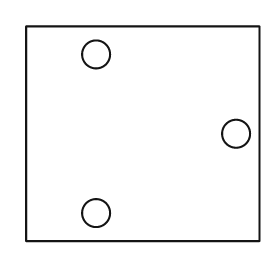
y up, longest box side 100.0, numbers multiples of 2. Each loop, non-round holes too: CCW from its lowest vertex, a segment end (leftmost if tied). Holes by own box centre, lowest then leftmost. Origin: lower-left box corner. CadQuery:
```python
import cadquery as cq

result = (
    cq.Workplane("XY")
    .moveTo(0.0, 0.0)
    .lineTo(100.0, 0.0)
    .lineTo(100.0, 92.0)
    .lineTo(0.0, 92.0)
    .close()
    .moveTo(30.0, 12.0)
    .circle(6.0)
    .moveTo(90.0, 46.0)
    .circle(6.0)
    .moveTo(30.0, 80.0)
    .circle(6.0)
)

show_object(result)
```